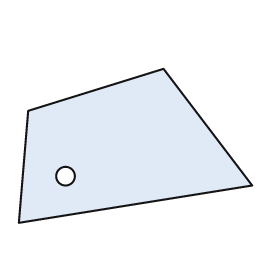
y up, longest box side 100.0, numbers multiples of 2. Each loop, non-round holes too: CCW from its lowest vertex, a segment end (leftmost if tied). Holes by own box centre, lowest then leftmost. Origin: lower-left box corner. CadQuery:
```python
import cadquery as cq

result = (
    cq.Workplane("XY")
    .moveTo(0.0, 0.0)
    .lineTo(100.0, 16.0)
    .lineTo(62.0, 66.0)
    .lineTo(4.0, 48.0)
    .close()
    .moveTo(20.0, 20.0)
    .circle(4.0)
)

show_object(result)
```